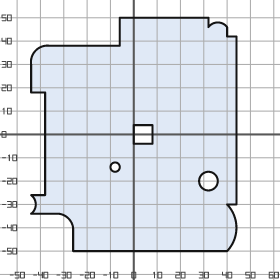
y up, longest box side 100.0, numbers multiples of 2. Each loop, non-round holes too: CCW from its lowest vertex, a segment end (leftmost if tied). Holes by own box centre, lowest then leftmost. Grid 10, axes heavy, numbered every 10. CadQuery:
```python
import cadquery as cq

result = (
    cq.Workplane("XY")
    .moveTo(-26.0, -50.0)
    .lineTo(40.0, -50.0)
    .threePointArc((44.0, -40.0), (40.0, -30.0))
    .lineTo(44.0, -30.0)
    .lineTo(44.0, 42.0)
    .lineTo(40.0, 42.0)
    .lineTo(40.0, 46.0)
    .threePointArc((36.0, 48.0), (32.0, 46.0))
    .lineTo(32.0, 50.0)
    .lineTo(-6.0, 50.0)
    .lineTo(-6.0, 38.0)
    .lineTo(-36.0, 38.0)
    .threePointArc((-42.0, 36.0), (-44.0, 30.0))
    .lineTo(-44.0, 18.0)
    .lineTo(-38.0, 18.0)
    .lineTo(-38.0, -26.0)
    .lineTo(-44.0, -26.0)
    .threePointArc((-42.0, -30.0), (-44.0, -34.0))
    .lineTo(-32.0, -34.0)
    .threePointArc((-28.0, -36.0), (-26.0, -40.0))
    .close()
    .moveTo(32.0, -20.0)
    .circle(4.0)
    .moveTo(-8.0, -14.0)
    .circle(2.0)
    .moveTo(0.0, -4.0)
    .lineTo(8.0, -4.0)
    .lineTo(8.0, 4.0)
    .lineTo(0.0, 4.0)
    .close()
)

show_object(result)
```